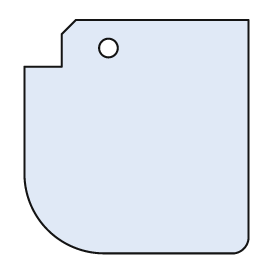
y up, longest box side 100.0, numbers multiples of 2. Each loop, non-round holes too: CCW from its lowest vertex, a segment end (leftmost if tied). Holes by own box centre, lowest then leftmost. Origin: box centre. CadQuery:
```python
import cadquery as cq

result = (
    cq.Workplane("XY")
    .moveTo(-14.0, -50.0)
    .lineTo(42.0, -50.0)
    .threePointArc((46.0, -48.0), (48.0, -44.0))
    .lineTo(48.0, 50.0)
    .lineTo(-26.0, 50.0)
    .lineTo(-32.0, 44.0)
    .lineTo(-32.0, 30.0)
    .lineTo(-48.0, 30.0)
    .lineTo(-48.0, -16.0)
    .threePointArc((-38.0, -40.0), (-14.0, -50.0))
    .close()
    .moveTo(-12.0, 38.0)
    .circle(4.0)
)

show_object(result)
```